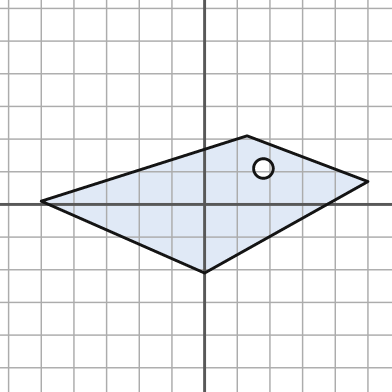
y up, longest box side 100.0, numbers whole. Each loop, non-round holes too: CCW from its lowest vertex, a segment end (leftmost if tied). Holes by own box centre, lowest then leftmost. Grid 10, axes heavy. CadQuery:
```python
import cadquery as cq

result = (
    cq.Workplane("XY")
    .moveTo(0.0, -21.0)
    .lineTo(50.0, 7.0)
    .lineTo(13.0, 21.0)
    .lineTo(-50.0, 1.0)
    .close()
    .moveTo(18.0, 11.0)
    .circle(3.0)
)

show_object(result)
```